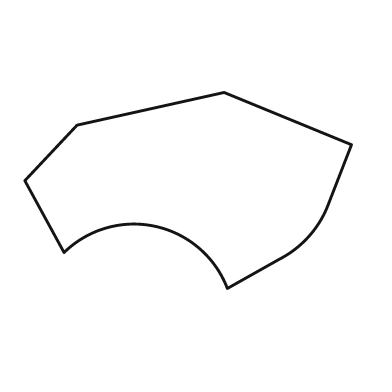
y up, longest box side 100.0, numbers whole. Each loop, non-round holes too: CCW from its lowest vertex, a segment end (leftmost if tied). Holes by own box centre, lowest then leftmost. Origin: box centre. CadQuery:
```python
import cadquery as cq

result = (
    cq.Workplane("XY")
    .moveTo(12.0, -30.0)
    .lineTo(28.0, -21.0)
    .threePointArc((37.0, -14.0), (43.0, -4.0))
    .lineTo(50.0, 14.0)
    .lineTo(11.0, 30.0)
    .lineTo(-34.0, 20.0)
    .lineTo(-50.0, 3.0)
    .lineTo(-38.0, -19.0)
    .threePointArc((-10.0, -11.0), (12.0, -30.0))
    .close()
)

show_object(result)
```